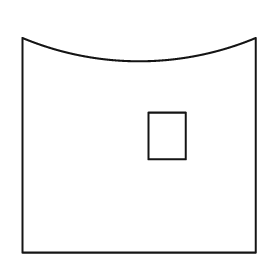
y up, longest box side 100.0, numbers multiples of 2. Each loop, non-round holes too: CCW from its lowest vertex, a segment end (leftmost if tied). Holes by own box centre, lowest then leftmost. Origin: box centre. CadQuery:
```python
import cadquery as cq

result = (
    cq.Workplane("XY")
    .moveTo(-50.0, -46.0)
    .lineTo(50.0, -46.0)
    .lineTo(50.0, 46.0)
    .threePointArc((0.0, 36.0), (-50.0, 46.0))
    .close()
    .moveTo(4.0, -6.0)
    .lineTo(20.0, -6.0)
    .lineTo(20.0, 14.0)
    .lineTo(4.0, 14.0)
    .close()
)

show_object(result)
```